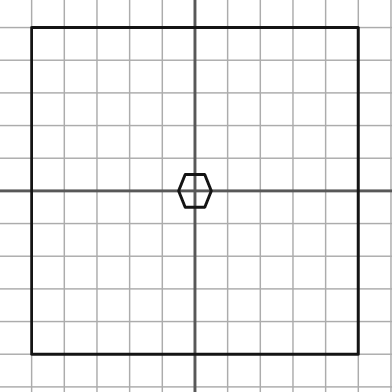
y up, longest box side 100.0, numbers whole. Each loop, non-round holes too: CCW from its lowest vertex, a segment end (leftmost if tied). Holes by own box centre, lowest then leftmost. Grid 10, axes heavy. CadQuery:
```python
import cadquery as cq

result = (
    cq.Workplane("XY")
    .moveTo(-50.0, -50.0)
    .lineTo(50.0, -50.0)
    .lineTo(50.0, 50.0)
    .lineTo(-50.0, 50.0)
    .close()
    .moveTo(-3.0, -5.0)
    .lineTo(3.0, -5.0)
    .lineTo(5.0, 0.0)
    .lineTo(3.0, 5.0)
    .lineTo(-3.0, 5.0)
    .lineTo(-5.0, 0.0)
    .close()
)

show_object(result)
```